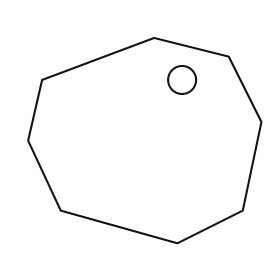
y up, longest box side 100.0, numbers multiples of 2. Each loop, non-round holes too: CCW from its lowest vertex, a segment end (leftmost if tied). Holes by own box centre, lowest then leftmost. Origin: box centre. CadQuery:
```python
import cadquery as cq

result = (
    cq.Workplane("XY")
    .moveTo(14.0, -44.0)
    .lineTo(42.0, -30.0)
    .lineTo(50.0, 8.0)
    .lineTo(36.0, 36.0)
    .lineTo(4.0, 44.0)
    .lineTo(-44.0, 26.0)
    .lineTo(-50.0, 0.0)
    .lineTo(-36.0, -30.0)
    .close()
    .moveTo(16.0, 26.0)
    .circle(6.0)
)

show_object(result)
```